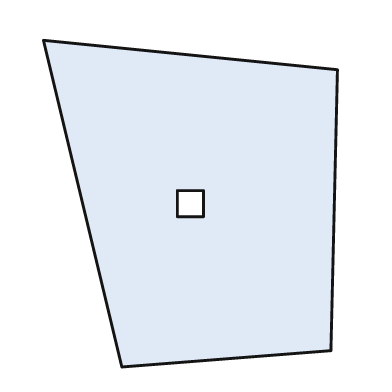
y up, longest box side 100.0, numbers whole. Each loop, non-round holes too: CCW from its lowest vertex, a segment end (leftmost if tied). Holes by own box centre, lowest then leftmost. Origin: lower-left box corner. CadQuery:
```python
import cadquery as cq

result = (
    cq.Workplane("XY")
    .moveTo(24.0, 0.0)
    .lineTo(88.0, 5.0)
    .lineTo(90.0, 91.0)
    .lineTo(0.0, 100.0)
    .close()
    .moveTo(41.0, 46.0)
    .lineTo(49.0, 46.0)
    .lineTo(49.0, 54.0)
    .lineTo(41.0, 54.0)
    .close()
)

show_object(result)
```